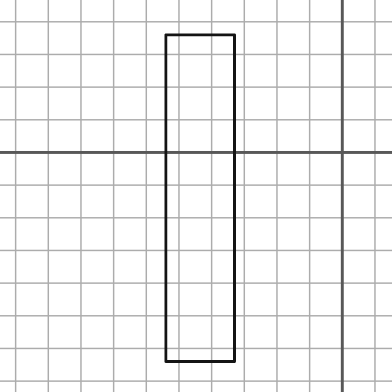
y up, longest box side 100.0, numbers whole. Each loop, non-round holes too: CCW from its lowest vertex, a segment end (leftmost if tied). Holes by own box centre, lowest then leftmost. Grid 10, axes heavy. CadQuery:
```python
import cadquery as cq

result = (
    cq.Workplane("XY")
    .moveTo(-54.0, -64.0)
    .lineTo(-33.0, -64.0)
    .lineTo(-33.0, 36.0)
    .lineTo(-54.0, 36.0)
    .close()
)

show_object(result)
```